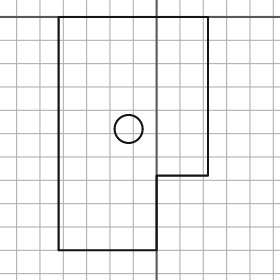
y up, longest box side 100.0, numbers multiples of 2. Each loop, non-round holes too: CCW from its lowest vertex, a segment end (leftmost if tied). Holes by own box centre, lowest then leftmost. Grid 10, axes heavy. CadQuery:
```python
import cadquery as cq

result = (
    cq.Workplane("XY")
    .moveTo(-42.0, -100.0)
    .lineTo(0.0, -100.0)
    .lineTo(0.0, -68.0)
    .lineTo(22.0, -68.0)
    .lineTo(22.0, 0.0)
    .lineTo(-42.0, 0.0)
    .close()
    .moveTo(-12.0, -48.0)
    .circle(6.0)
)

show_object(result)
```